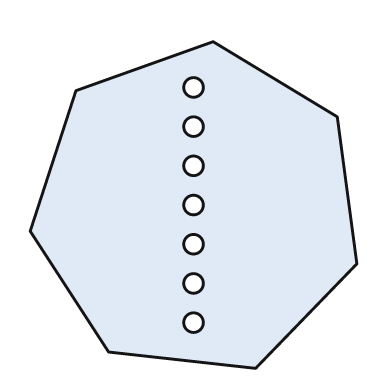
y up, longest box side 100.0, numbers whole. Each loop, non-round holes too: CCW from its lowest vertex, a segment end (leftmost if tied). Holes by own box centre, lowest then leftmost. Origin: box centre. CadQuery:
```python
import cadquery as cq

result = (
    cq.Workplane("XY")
    .moveTo(19.0, -50.0)
    .lineTo(50.0, -18.0)
    .lineTo(44.0, 27.0)
    .lineTo(6.0, 50.0)
    .lineTo(-36.0, 35.0)
    .lineTo(-50.0, -8.0)
    .lineTo(-26.0, -45.0)
    .close()
    .moveTo(0.0, -36.0)
    .circle(3.0)
    .moveTo(0.0, -24.0)
    .circle(3.0)
    .moveTo(0.0, -12.0)
    .circle(3.0)
    .moveTo(0.0, 0.0)
    .circle(3.0)
    .moveTo(0.0, 12.0)
    .circle(3.0)
    .moveTo(0.0, 24.0)
    .circle(3.0)
    .moveTo(0.0, 36.0)
    .circle(3.0)
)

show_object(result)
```